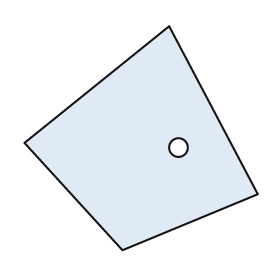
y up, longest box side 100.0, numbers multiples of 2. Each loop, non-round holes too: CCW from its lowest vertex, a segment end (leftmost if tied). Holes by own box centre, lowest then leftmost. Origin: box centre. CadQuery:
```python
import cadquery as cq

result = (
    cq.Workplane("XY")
    .moveTo(-8.0, -48.0)
    .lineTo(50.0, -24.0)
    .lineTo(12.0, 48.0)
    .lineTo(-50.0, -2.0)
    .close()
    .moveTo(16.0, -4.0)
    .circle(4.0)
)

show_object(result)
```